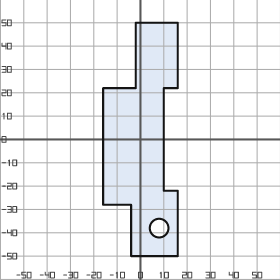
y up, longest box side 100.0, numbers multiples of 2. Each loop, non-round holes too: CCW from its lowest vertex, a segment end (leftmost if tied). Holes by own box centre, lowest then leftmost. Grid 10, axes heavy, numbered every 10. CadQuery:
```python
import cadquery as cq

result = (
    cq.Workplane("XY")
    .moveTo(-4.0, -50.0)
    .lineTo(16.0, -50.0)
    .lineTo(16.0, -22.0)
    .lineTo(10.0, -22.0)
    .lineTo(10.0, 22.0)
    .lineTo(16.0, 22.0)
    .lineTo(16.0, 50.0)
    .lineTo(-2.0, 50.0)
    .lineTo(-2.0, 22.0)
    .lineTo(-16.0, 22.0)
    .lineTo(-16.0, -28.0)
    .lineTo(-4.0, -28.0)
    .close()
    .moveTo(8.0, -38.0)
    .circle(4.0)
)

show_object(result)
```